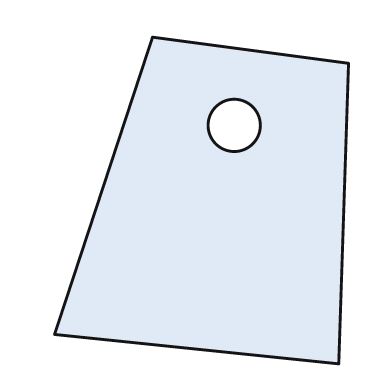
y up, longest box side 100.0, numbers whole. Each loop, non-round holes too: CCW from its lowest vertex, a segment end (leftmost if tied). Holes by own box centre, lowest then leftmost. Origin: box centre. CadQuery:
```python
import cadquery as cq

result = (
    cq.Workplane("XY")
    .moveTo(42.0, -50.0)
    .lineTo(45.0, 42.0)
    .lineTo(-15.0, 50.0)
    .lineTo(-45.0, -41.0)
    .close()
    .moveTo(10.0, 23.0)
    .circle(8.0)
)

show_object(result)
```